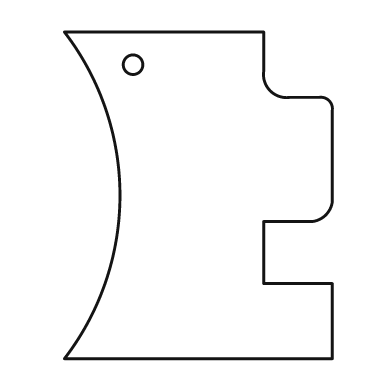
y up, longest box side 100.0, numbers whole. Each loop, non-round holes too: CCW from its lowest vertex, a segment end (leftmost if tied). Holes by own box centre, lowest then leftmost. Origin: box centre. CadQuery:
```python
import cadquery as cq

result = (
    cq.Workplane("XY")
    .moveTo(-41.0, -50.0)
    .lineTo(41.0, -50.0)
    .lineTo(41.0, -27.0)
    .lineTo(20.0, -27.0)
    .lineTo(20.0, -8.0)
    .lineTo(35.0, -8.0)
    .threePointArc((39.0, -6.0), (41.0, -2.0))
    .lineTo(41.0, 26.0)
    .threePointArc((40.0, 29.0), (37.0, 30.0))
    .lineTo(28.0, 30.0)
    .threePointArc((22.0, 32.0), (20.0, 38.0))
    .lineTo(20.0, 50.0)
    .lineTo(-41.0, 50.0)
    .threePointArc((-24.0, 0.0), (-41.0, -50.0))
    .close()
    .moveTo(-20.0, 40.0)
    .circle(3.0)
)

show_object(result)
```